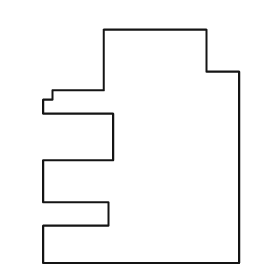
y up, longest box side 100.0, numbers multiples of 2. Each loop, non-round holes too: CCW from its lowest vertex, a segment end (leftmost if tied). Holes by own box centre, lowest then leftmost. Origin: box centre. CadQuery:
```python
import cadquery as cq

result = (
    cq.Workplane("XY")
    .moveTo(-42.0, -50.0)
    .lineTo(42.0, -50.0)
    .lineTo(42.0, 32.0)
    .lineTo(28.0, 32.0)
    .lineTo(28.0, 50.0)
    .lineTo(-16.0, 50.0)
    .lineTo(-16.0, 24.0)
    .lineTo(-38.0, 24.0)
    .lineTo(-38.0, 20.0)
    .lineTo(-42.0, 20.0)
    .lineTo(-42.0, 14.0)
    .lineTo(-12.0, 14.0)
    .lineTo(-12.0, -6.0)
    .lineTo(-42.0, -6.0)
    .lineTo(-42.0, -24.0)
    .lineTo(-14.0, -24.0)
    .lineTo(-14.0, -34.0)
    .lineTo(-42.0, -34.0)
    .close()
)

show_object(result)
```